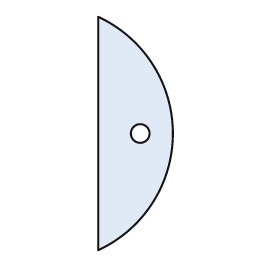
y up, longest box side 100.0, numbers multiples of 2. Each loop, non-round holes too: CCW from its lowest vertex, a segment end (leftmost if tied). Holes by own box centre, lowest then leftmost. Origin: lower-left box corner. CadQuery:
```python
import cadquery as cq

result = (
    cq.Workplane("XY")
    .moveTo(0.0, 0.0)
    .threePointArc((32.0, 50.0), (0.0, 100.0))
    .close()
    .moveTo(18.0, 50.0)
    .circle(4.0)
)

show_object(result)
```